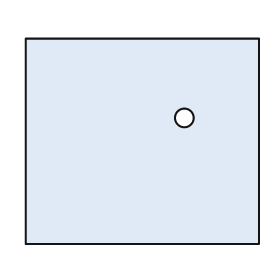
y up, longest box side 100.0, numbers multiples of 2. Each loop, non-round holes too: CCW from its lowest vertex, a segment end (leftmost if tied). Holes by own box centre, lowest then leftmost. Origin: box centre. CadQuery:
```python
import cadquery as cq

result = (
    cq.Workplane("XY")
    .moveTo(-50.0, -44.0)
    .lineTo(50.0, -44.0)
    .lineTo(50.0, 44.0)
    .lineTo(-50.0, 44.0)
    .close()
    .moveTo(18.0, 10.0)
    .circle(4.0)
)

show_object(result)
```